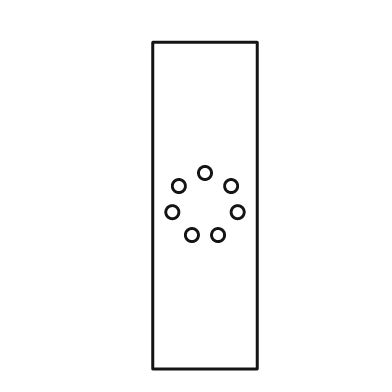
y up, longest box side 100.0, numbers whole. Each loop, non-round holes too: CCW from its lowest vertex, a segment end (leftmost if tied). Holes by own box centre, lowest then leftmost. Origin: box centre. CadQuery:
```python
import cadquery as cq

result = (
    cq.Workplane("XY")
    .moveTo(-16.0, -50.0)
    .lineTo(16.0, -50.0)
    .lineTo(16.0, 50.0)
    .lineTo(-16.0, 50.0)
    .close()
    .moveTo(-4.0, -9.0)
    .circle(2.0)
    .moveTo(4.0, -9.0)
    .circle(2.0)
    .moveTo(-10.0, -2.0)
    .circle(2.0)
    .moveTo(10.0, -2.0)
    .circle(2.0)
    .moveTo(-8.0, 6.0)
    .circle(2.0)
    .moveTo(8.0, 6.0)
    .circle(2.0)
    .moveTo(0.0, 10.0)
    .circle(2.0)
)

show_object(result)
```